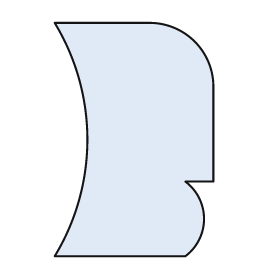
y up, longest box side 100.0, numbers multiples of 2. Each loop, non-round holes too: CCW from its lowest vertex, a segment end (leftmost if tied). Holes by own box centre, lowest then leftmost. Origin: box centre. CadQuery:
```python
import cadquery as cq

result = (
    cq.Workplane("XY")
    .moveTo(-34.0, -50.0)
    .lineTo(22.0, -50.0)
    .threePointArc((30.0, -34.0), (22.0, -18.0))
    .lineTo(34.0, -18.0)
    .lineTo(34.0, 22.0)
    .threePointArc((26.0, 42.0), (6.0, 50.0))
    .lineTo(-34.0, 50.0)
    .threePointArc((-20.0, 0.0), (-34.0, -50.0))
    .close()
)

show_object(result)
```